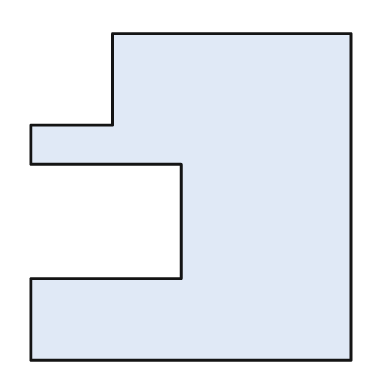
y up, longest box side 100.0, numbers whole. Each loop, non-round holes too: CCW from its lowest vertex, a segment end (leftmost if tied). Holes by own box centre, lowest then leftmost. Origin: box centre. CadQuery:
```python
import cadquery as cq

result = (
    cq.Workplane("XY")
    .moveTo(-49.0, -50.0)
    .lineTo(49.0, -50.0)
    .lineTo(49.0, 50.0)
    .lineTo(-24.0, 50.0)
    .lineTo(-24.0, 22.0)
    .lineTo(-49.0, 22.0)
    .lineTo(-49.0, 10.0)
    .lineTo(-3.0, 10.0)
    .lineTo(-3.0, -25.0)
    .lineTo(-49.0, -25.0)
    .close()
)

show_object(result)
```